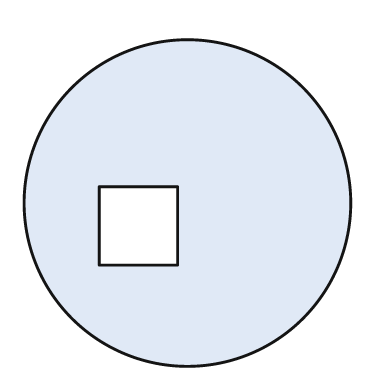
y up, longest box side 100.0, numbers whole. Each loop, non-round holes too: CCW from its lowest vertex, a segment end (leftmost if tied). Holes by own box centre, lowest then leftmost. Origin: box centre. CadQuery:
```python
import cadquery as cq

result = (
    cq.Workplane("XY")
    .moveTo(0.0, 0.0)
    .circle(50.0)
    .moveTo(-27.0, -19.0)
    .lineTo(-3.0, -19.0)
    .lineTo(-3.0, 5.0)
    .lineTo(-27.0, 5.0)
    .close()
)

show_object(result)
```